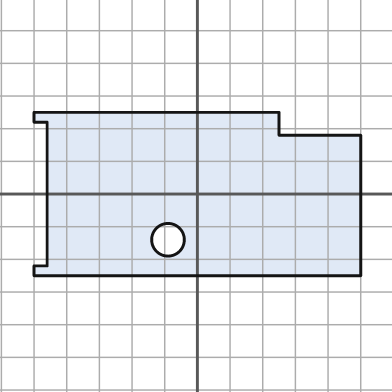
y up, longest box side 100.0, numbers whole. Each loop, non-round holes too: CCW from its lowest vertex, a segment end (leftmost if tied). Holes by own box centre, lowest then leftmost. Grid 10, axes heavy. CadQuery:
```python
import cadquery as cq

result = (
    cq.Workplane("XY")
    .moveTo(-50.0, -25.0)
    .lineTo(50.0, -25.0)
    .lineTo(50.0, 18.0)
    .lineTo(25.0, 18.0)
    .lineTo(25.0, 25.0)
    .lineTo(-50.0, 25.0)
    .lineTo(-50.0, 22.0)
    .lineTo(-46.0, 22.0)
    .lineTo(-46.0, -22.0)
    .lineTo(-50.0, -22.0)
    .close()
    .moveTo(-9.0, -14.0)
    .circle(5.0)
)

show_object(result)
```